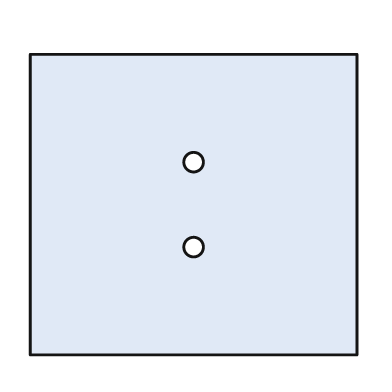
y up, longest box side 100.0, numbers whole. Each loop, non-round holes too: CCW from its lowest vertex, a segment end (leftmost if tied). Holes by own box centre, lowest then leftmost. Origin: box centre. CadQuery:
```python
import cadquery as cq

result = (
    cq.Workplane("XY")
    .moveTo(-50.0, -46.0)
    .lineTo(50.0, -46.0)
    .lineTo(50.0, 46.0)
    .lineTo(-50.0, 46.0)
    .close()
    .moveTo(0.0, -13.0)
    .circle(3.0)
    .moveTo(0.0, 13.0)
    .circle(3.0)
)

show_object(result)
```